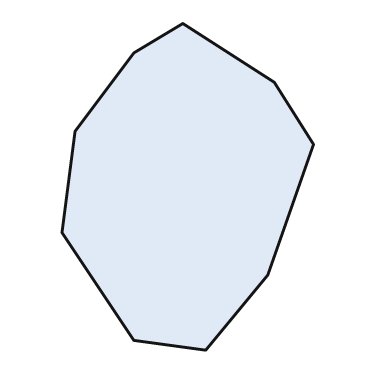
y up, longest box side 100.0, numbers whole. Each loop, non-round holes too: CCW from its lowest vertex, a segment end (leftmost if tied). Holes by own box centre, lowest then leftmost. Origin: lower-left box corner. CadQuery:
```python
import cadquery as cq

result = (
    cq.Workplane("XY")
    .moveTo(44.0, 0.0)
    .lineTo(63.0, 23.0)
    .lineTo(77.0, 63.0)
    .lineTo(65.0, 82.0)
    .lineTo(37.0, 100.0)
    .lineTo(22.0, 91.0)
    .lineTo(4.0, 67.0)
    .lineTo(0.0, 36.0)
    .lineTo(22.0, 3.0)
    .close()
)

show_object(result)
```